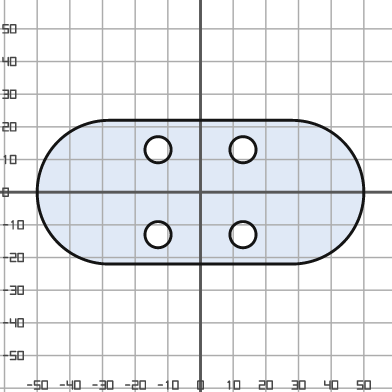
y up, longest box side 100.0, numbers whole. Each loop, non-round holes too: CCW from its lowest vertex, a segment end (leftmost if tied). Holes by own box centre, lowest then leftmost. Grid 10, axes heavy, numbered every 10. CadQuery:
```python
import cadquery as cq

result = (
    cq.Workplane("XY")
    .moveTo(-28.0, -22.0)
    .lineTo(28.0, -22.0)
    .threePointArc((50.0, 0.0), (28.0, 22.0))
    .lineTo(-28.0, 22.0)
    .threePointArc((-50.0, 0.0), (-28.0, -22.0))
    .close()
    .moveTo(-13.0, -13.0)
    .circle(4.0)
    .moveTo(13.0, -13.0)
    .circle(4.0)
    .moveTo(-13.0, 13.0)
    .circle(4.0)
    .moveTo(13.0, 13.0)
    .circle(4.0)
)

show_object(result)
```